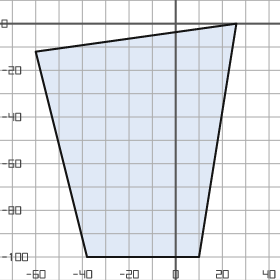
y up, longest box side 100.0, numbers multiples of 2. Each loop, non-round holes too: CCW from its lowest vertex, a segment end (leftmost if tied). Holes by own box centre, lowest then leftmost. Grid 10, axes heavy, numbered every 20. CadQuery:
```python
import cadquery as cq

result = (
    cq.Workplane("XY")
    .moveTo(-38.0, -100.0)
    .lineTo(10.0, -100.0)
    .lineTo(26.0, 0.0)
    .lineTo(-60.0, -12.0)
    .close()
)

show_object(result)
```